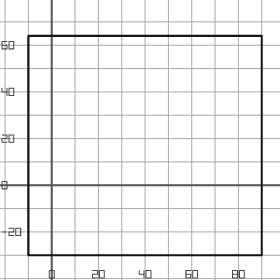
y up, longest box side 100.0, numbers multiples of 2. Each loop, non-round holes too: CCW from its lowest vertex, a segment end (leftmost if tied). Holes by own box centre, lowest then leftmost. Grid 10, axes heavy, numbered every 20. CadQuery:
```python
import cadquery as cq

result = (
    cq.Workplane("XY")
    .moveTo(-10.0, -30.0)
    .lineTo(90.0, -30.0)
    .lineTo(90.0, 64.0)
    .lineTo(-10.0, 64.0)
    .close()
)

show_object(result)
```